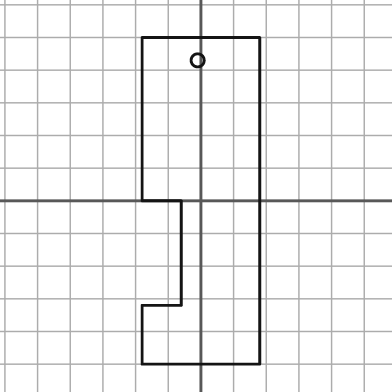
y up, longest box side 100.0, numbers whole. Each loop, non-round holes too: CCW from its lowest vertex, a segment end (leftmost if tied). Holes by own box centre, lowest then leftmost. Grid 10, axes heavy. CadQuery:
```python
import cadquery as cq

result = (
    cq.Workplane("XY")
    .moveTo(-18.0, -50.0)
    .lineTo(18.0, -50.0)
    .lineTo(18.0, 50.0)
    .lineTo(-18.0, 50.0)
    .lineTo(-18.0, 0.0)
    .lineTo(-6.0, 0.0)
    .lineTo(-6.0, -32.0)
    .lineTo(-18.0, -32.0)
    .close()
    .moveTo(-1.0, 43.0)
    .circle(2.0)
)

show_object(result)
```